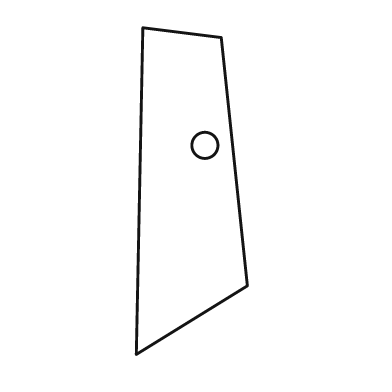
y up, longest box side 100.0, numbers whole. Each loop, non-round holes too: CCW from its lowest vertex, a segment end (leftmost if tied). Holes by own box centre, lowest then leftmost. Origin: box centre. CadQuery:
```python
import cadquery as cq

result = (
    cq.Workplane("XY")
    .moveTo(-17.0, -50.0)
    .lineTo(17.0, -29.0)
    .lineTo(9.0, 47.0)
    .lineTo(-15.0, 50.0)
    .close()
    .moveTo(4.0, 14.0)
    .circle(4.0)
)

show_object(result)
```